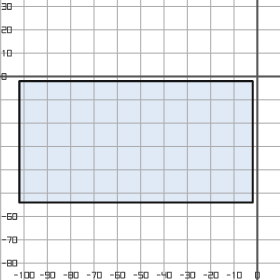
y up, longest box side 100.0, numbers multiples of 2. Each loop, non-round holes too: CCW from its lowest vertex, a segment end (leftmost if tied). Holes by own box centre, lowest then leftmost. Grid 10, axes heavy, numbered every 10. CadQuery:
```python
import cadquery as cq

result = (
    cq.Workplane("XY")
    .moveTo(-102.0, -54.0)
    .lineTo(-2.0, -54.0)
    .lineTo(-2.0, -2.0)
    .lineTo(-102.0, -2.0)
    .close()
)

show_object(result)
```